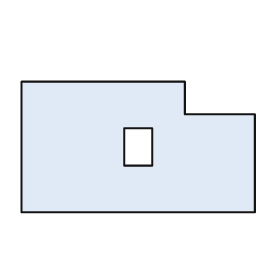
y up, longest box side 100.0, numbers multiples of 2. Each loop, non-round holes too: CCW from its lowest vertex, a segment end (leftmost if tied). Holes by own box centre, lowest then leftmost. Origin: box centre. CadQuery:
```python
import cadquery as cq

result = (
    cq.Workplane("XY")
    .moveTo(-50.0, -28.0)
    .lineTo(50.0, -28.0)
    .lineTo(50.0, 14.0)
    .lineTo(20.0, 14.0)
    .lineTo(20.0, 28.0)
    .lineTo(-50.0, 28.0)
    .close()
    .moveTo(-6.0, -8.0)
    .lineTo(6.0, -8.0)
    .lineTo(6.0, 8.0)
    .lineTo(-6.0, 8.0)
    .close()
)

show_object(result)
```